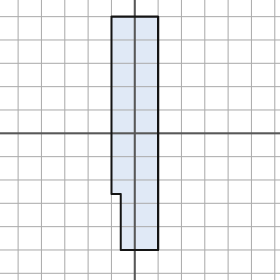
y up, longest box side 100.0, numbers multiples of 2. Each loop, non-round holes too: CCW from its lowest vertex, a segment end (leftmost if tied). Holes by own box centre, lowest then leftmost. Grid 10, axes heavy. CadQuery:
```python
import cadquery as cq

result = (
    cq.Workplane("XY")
    .moveTo(-6.0, -50.0)
    .lineTo(10.0, -50.0)
    .lineTo(10.0, 50.0)
    .lineTo(-10.0, 50.0)
    .lineTo(-10.0, -26.0)
    .lineTo(-6.0, -26.0)
    .close()
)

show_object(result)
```